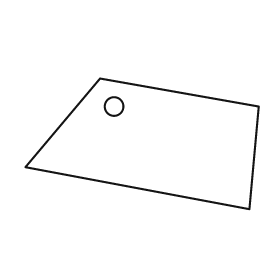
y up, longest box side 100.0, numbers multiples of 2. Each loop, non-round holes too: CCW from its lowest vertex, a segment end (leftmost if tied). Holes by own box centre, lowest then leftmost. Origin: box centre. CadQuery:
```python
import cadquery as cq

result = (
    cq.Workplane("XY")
    .moveTo(46.0, -28.0)
    .lineTo(50.0, 16.0)
    .lineTo(-18.0, 28.0)
    .lineTo(-50.0, -10.0)
    .close()
    .moveTo(-12.0, 16.0)
    .circle(4.0)
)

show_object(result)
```